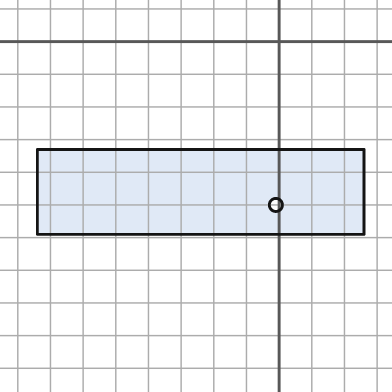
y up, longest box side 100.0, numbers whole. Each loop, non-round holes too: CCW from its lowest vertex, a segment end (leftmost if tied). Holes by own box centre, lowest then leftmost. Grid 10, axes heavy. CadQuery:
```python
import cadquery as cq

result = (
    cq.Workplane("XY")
    .moveTo(-74.0, -59.0)
    .lineTo(26.0, -59.0)
    .lineTo(26.0, -33.0)
    .lineTo(-74.0, -33.0)
    .close()
    .moveTo(-1.0, -50.0)
    .circle(2.0)
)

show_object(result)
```